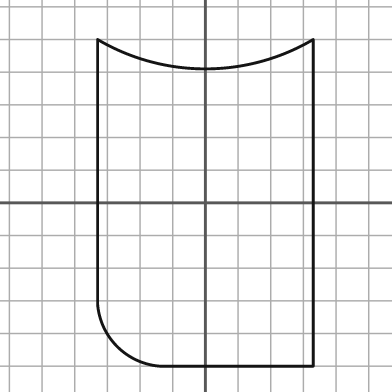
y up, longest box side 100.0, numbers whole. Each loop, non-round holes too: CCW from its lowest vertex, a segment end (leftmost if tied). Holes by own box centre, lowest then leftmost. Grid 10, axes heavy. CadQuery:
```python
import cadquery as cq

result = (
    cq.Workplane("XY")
    .moveTo(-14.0, -50.0)
    .lineTo(33.0, -50.0)
    .lineTo(33.0, 50.0)
    .threePointArc((0.0, 41.0), (-33.0, 50.0))
    .lineTo(-33.0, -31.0)
    .threePointArc((-27.0, -44.0), (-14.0, -50.0))
    .close()
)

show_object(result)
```